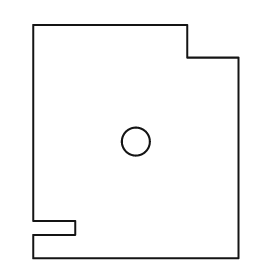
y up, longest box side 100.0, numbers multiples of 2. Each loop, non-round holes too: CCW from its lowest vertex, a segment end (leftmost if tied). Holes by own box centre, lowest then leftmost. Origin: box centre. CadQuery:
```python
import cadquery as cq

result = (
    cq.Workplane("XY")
    .moveTo(-44.0, -50.0)
    .lineTo(44.0, -50.0)
    .lineTo(44.0, 36.0)
    .lineTo(22.0, 36.0)
    .lineTo(22.0, 50.0)
    .lineTo(-44.0, 50.0)
    .lineTo(-44.0, -34.0)
    .lineTo(-26.0, -34.0)
    .lineTo(-26.0, -40.0)
    .lineTo(-44.0, -40.0)
    .close()
    .moveTo(0.0, 0.0)
    .circle(6.0)
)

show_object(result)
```